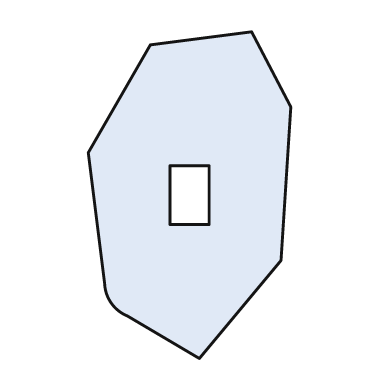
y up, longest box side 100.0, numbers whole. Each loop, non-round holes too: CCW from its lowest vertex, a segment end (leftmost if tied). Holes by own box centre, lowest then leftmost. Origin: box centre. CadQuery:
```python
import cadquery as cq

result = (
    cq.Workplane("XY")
    .moveTo(3.0, -50.0)
    .lineTo(28.0, -20.0)
    .lineTo(31.0, 27.0)
    .lineTo(19.0, 50.0)
    .lineTo(-12.0, 46.0)
    .lineTo(-31.0, 13.0)
    .lineTo(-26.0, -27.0)
    .threePointArc((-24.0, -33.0), (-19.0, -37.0))
    .close()
    .moveTo(-6.0, -9.0)
    .lineTo(6.0, -9.0)
    .lineTo(6.0, 9.0)
    .lineTo(-6.0, 9.0)
    .close()
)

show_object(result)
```